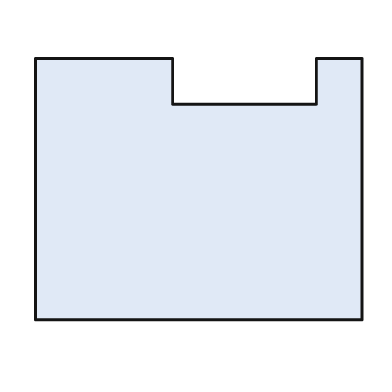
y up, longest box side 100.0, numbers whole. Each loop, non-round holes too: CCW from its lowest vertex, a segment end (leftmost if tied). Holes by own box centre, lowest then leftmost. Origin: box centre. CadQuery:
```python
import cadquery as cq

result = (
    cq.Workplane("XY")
    .moveTo(-50.0, -40.0)
    .lineTo(50.0, -40.0)
    .lineTo(50.0, 40.0)
    .lineTo(36.0, 40.0)
    .lineTo(36.0, 26.0)
    .lineTo(-8.0, 26.0)
    .lineTo(-8.0, 40.0)
    .lineTo(-50.0, 40.0)
    .close()
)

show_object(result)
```